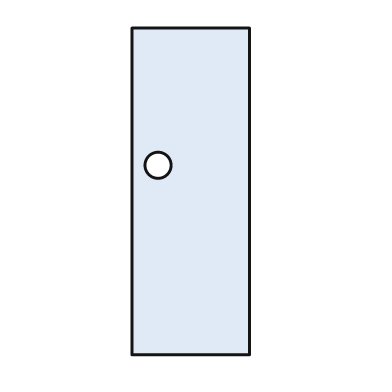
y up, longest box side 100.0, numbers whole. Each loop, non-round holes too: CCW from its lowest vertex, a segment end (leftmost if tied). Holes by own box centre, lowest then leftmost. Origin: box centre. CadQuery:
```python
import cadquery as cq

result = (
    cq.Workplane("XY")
    .moveTo(-18.0, -50.0)
    .lineTo(18.0, -50.0)
    .lineTo(18.0, 50.0)
    .lineTo(-18.0, 50.0)
    .close()
    .moveTo(-10.0, 8.0)
    .circle(4.0)
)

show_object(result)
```